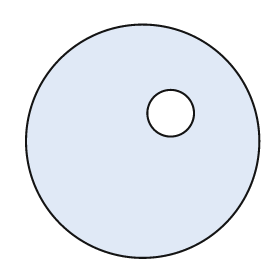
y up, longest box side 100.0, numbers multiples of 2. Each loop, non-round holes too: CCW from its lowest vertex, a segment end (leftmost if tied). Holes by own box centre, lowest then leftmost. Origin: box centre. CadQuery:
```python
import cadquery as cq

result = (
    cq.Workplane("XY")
    .moveTo(0.0, 0.0)
    .circle(50.0)
    .moveTo(12.0, 12.0)
    .circle(10.0)
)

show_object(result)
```